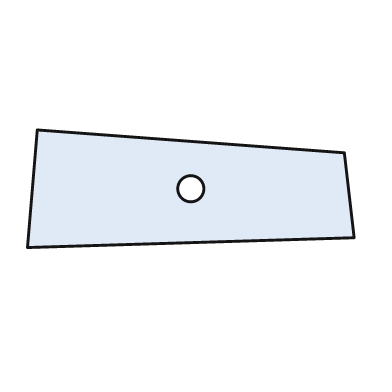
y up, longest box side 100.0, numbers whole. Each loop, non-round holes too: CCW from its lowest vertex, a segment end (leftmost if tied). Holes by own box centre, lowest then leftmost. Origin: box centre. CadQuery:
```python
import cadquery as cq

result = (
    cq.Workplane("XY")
    .moveTo(-50.0, -18.0)
    .lineTo(50.0, -15.0)
    .lineTo(47.0, 11.0)
    .lineTo(-47.0, 18.0)
    .close()
    .moveTo(0.0, 0.0)
    .circle(4.0)
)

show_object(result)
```